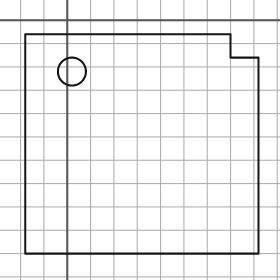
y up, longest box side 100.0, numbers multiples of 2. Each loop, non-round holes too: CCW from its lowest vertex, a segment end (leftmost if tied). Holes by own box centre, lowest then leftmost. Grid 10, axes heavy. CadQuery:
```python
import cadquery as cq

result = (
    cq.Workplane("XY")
    .moveTo(-18.0, -100.0)
    .lineTo(82.0, -100.0)
    .lineTo(82.0, -16.0)
    .lineTo(70.0, -16.0)
    .lineTo(70.0, -6.0)
    .lineTo(-18.0, -6.0)
    .close()
    .moveTo(2.0, -22.0)
    .circle(6.0)
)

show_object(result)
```